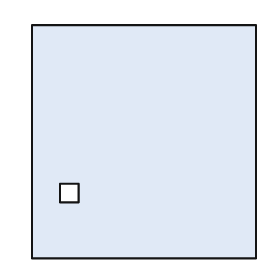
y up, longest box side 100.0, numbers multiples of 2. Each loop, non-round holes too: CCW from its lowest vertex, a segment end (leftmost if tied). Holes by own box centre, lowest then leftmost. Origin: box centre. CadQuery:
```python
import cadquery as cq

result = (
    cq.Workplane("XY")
    .moveTo(-48.0, -50.0)
    .lineTo(48.0, -50.0)
    .lineTo(48.0, 50.0)
    .lineTo(-48.0, 50.0)
    .close()
    .moveTo(-36.0, -26.0)
    .lineTo(-28.0, -26.0)
    .lineTo(-28.0, -18.0)
    .lineTo(-36.0, -18.0)
    .close()
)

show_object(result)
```